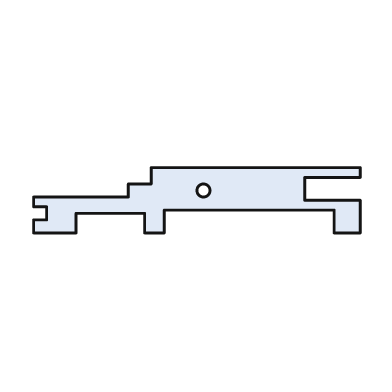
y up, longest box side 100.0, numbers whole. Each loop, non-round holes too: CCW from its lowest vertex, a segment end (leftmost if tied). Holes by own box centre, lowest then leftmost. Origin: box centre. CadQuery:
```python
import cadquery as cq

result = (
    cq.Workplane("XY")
    .moveTo(-50.0, -10.0)
    .lineTo(-37.0, -10.0)
    .lineTo(-37.0, -4.0)
    .lineTo(-16.0, -4.0)
    .lineTo(-16.0, -10.0)
    .lineTo(-10.0, -10.0)
    .lineTo(-10.0, -3.0)
    .lineTo(42.0, -3.0)
    .lineTo(42.0, -10.0)
    .lineTo(50.0, -10.0)
    .lineTo(50.0, 0.0)
    .lineTo(33.0, 0.0)
    .lineTo(33.0, 7.0)
    .lineTo(50.0, 7.0)
    .lineTo(50.0, 10.0)
    .lineTo(-14.0, 10.0)
    .lineTo(-14.0, 5.0)
    .lineTo(-21.0, 5.0)
    .lineTo(-21.0, 1.0)
    .lineTo(-50.0, 1.0)
    .lineTo(-50.0, -2.0)
    .lineTo(-46.0, -2.0)
    .lineTo(-46.0, -6.0)
    .lineTo(-50.0, -6.0)
    .close()
    .moveTo(2.0, 3.0)
    .circle(2.0)
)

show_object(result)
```